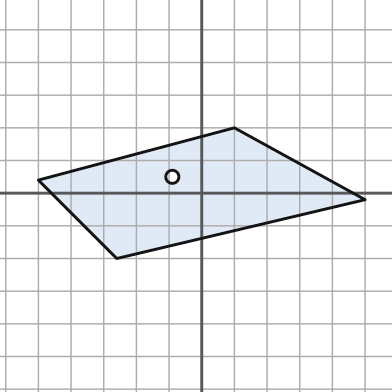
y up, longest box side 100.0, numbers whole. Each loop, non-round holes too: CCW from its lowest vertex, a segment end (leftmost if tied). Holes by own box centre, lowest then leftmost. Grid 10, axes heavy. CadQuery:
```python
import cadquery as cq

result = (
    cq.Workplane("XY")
    .moveTo(-26.0, -20.0)
    .lineTo(50.0, -2.0)
    .lineTo(10.0, 20.0)
    .lineTo(-50.0, 4.0)
    .close()
    .moveTo(-9.0, 5.0)
    .circle(2.0)
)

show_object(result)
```